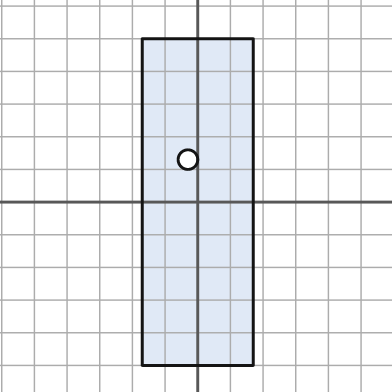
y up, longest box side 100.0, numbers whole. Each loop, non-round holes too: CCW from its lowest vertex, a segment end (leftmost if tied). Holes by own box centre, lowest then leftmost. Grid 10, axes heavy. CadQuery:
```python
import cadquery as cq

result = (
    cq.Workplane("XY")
    .moveTo(-17.0, -50.0)
    .lineTo(17.0, -50.0)
    .lineTo(17.0, 50.0)
    .lineTo(-17.0, 50.0)
    .close()
    .moveTo(-3.0, 13.0)
    .circle(3.0)
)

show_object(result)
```